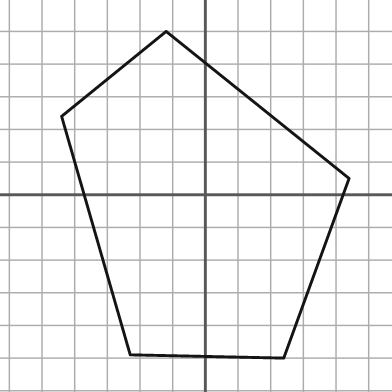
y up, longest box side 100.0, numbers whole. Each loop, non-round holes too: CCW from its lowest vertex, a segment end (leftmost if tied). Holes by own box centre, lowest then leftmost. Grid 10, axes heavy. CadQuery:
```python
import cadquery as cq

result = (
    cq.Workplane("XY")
    .moveTo(24.0, -50.0)
    .lineTo(44.0, 5.0)
    .lineTo(-12.0, 50.0)
    .lineTo(-44.0, 24.0)
    .lineTo(-23.0, -49.0)
    .close()
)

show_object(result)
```